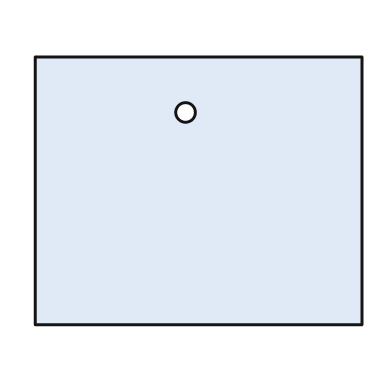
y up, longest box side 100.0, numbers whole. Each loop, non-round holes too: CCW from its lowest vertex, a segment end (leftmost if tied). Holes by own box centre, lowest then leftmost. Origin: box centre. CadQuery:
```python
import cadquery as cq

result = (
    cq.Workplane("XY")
    .moveTo(-50.0, -41.0)
    .lineTo(50.0, -41.0)
    .lineTo(50.0, 41.0)
    .lineTo(-50.0, 41.0)
    .close()
    .moveTo(-4.0, 24.0)
    .circle(3.0)
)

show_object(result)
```